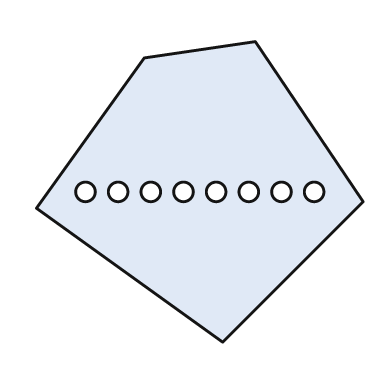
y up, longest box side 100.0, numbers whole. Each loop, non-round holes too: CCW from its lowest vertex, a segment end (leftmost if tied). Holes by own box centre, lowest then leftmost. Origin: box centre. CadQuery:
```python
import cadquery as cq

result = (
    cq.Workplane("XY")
    .moveTo(7.0, -46.0)
    .lineTo(50.0, -3.0)
    .lineTo(17.0, 46.0)
    .lineTo(-17.0, 41.0)
    .lineTo(-50.0, -5.0)
    .close()
    .moveTo(-35.0, 0.0)
    .circle(3.0)
    .moveTo(-25.0, 0.0)
    .circle(3.0)
    .moveTo(-15.0, 0.0)
    .circle(3.0)
    .moveTo(-5.0, 0.0)
    .circle(3.0)
    .moveTo(5.0, 0.0)
    .circle(3.0)
    .moveTo(15.0, 0.0)
    .circle(3.0)
    .moveTo(25.0, 0.0)
    .circle(3.0)
    .moveTo(35.0, 0.0)
    .circle(3.0)
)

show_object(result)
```